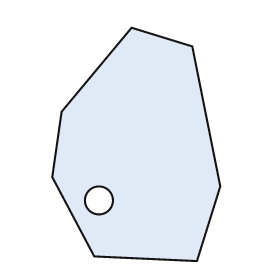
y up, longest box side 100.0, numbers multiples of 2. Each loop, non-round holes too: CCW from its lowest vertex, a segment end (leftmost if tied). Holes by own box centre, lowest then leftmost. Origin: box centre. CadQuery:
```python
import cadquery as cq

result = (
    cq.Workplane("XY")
    .moveTo(26.0, -50.0)
    .lineTo(36.0, -18.0)
    .lineTo(24.0, 42.0)
    .lineTo(-2.0, 50.0)
    .lineTo(-32.0, 14.0)
    .lineTo(-36.0, -14.0)
    .lineTo(-18.0, -48.0)
    .close()
    .moveTo(-16.0, -24.0)
    .circle(6.0)
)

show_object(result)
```